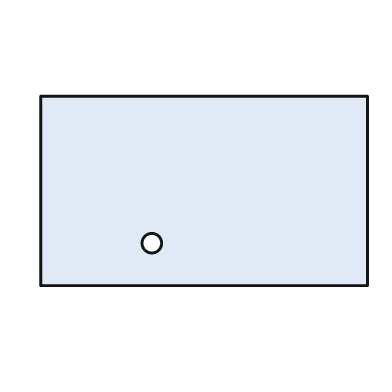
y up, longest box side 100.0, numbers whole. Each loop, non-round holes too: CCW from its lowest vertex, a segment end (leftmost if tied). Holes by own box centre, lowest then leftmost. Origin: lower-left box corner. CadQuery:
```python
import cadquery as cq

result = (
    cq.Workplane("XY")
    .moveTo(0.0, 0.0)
    .lineTo(100.0, 0.0)
    .lineTo(100.0, 58.0)
    .lineTo(0.0, 58.0)
    .close()
    .moveTo(34.0, 13.0)
    .circle(3.0)
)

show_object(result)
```